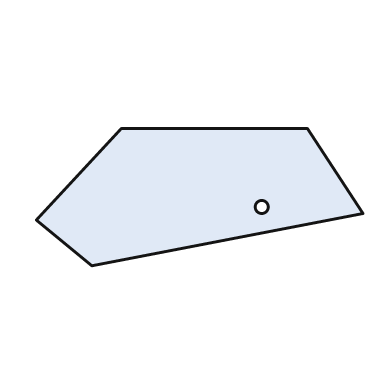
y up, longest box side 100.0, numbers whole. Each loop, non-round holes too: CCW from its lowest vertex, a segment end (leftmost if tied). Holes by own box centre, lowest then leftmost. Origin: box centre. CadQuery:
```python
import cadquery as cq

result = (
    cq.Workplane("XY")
    .moveTo(-33.0, -21.0)
    .lineTo(50.0, -5.0)
    .lineTo(33.0, 21.0)
    .lineTo(-24.0, 21.0)
    .lineTo(-50.0, -7.0)
    .close()
    .moveTo(19.0, -3.0)
    .circle(2.0)
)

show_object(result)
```